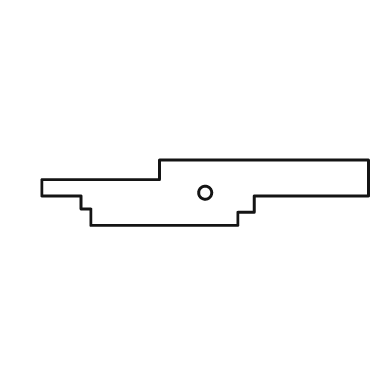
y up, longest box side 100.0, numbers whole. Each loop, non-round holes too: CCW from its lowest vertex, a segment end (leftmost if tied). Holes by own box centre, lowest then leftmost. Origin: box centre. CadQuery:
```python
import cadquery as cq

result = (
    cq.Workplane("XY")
    .moveTo(-35.0, -10.0)
    .lineTo(10.0, -10.0)
    .lineTo(10.0, -6.0)
    .lineTo(15.0, -6.0)
    .lineTo(15.0, -1.0)
    .lineTo(50.0, -1.0)
    .lineTo(50.0, 10.0)
    .lineTo(-14.0, 10.0)
    .lineTo(-14.0, 4.0)
    .lineTo(-50.0, 4.0)
    .lineTo(-50.0, -1.0)
    .lineTo(-38.0, -1.0)
    .lineTo(-38.0, -5.0)
    .lineTo(-35.0, -5.0)
    .close()
    .moveTo(0.0, 0.0)
    .circle(2.0)
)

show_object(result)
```